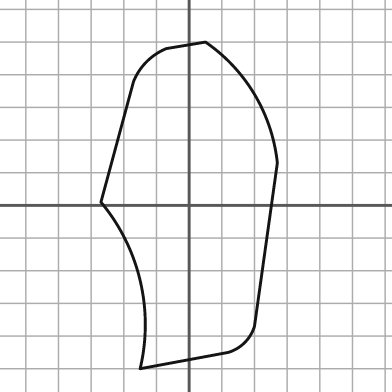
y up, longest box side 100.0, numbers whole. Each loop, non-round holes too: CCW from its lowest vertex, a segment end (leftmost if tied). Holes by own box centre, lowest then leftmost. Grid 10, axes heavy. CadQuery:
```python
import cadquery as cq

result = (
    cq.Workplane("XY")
    .moveTo(-15.0, -50.0)
    .lineTo(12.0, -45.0)
    .threePointArc((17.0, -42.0), (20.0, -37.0))
    .lineTo(27.0, 13.0)
    .threePointArc((20.0, 34.0), (5.0, 50.0))
    .lineTo(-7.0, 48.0)
    .threePointArc((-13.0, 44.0), (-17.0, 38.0))
    .lineTo(-27.0, 1.0)
    .threePointArc((-15.0, -23.0), (-15.0, -50.0))
    .close()
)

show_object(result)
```